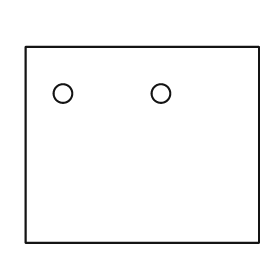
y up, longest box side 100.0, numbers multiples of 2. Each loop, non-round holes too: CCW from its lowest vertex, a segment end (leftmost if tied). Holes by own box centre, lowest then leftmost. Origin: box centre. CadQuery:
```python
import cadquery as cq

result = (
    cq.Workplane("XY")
    .moveTo(-50.0, -42.0)
    .lineTo(50.0, -42.0)
    .lineTo(50.0, 42.0)
    .lineTo(-50.0, 42.0)
    .close()
    .moveTo(-34.0, 22.0)
    .circle(4.0)
    .moveTo(8.0, 22.0)
    .circle(4.0)
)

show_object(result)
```